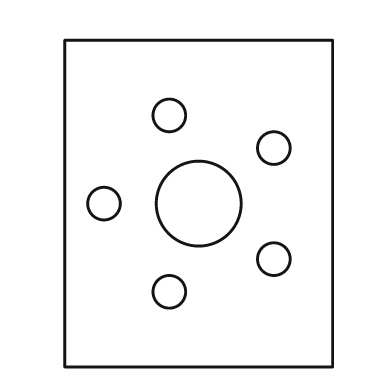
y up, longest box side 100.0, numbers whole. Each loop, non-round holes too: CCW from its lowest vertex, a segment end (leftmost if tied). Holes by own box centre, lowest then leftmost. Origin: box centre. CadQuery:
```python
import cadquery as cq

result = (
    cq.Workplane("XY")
    .moveTo(-41.0, -50.0)
    .lineTo(41.0, -50.0)
    .lineTo(41.0, 50.0)
    .lineTo(-41.0, 50.0)
    .close()
    .moveTo(-9.0, -27.0)
    .circle(5.0)
    .moveTo(23.0, -17.0)
    .circle(5.0)
    .moveTo(-29.0, 0.0)
    .circle(5.0)
    .moveTo(0.0, 0.0)
    .circle(13.0)
    .moveTo(23.0, 17.0)
    .circle(5.0)
    .moveTo(-9.0, 27.0)
    .circle(5.0)
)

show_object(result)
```